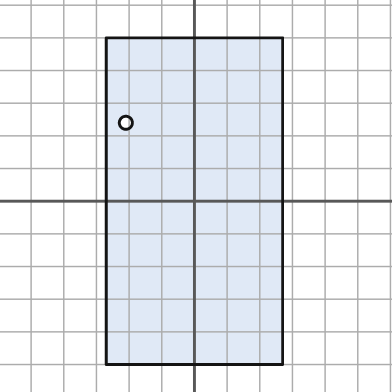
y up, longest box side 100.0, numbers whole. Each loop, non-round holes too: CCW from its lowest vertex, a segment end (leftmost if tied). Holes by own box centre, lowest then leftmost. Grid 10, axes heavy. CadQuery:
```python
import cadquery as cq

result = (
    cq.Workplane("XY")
    .moveTo(-27.0, -50.0)
    .lineTo(27.0, -50.0)
    .lineTo(27.0, 50.0)
    .lineTo(-27.0, 50.0)
    .close()
    .moveTo(-21.0, 24.0)
    .circle(2.0)
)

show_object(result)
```